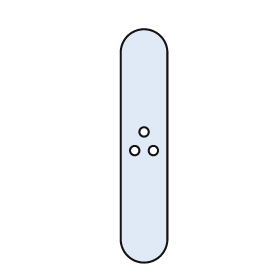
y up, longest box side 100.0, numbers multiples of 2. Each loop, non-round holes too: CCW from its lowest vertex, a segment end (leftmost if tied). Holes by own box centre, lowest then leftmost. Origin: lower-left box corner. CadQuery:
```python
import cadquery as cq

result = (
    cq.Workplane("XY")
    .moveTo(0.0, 10.0)
    .threePointArc((10.0, 0.0), (20.0, 10.0))
    .lineTo(20.0, 90.0)
    .threePointArc((10.0, 100.0), (0.0, 90.0))
    .close()
    .moveTo(6.0, 48.0)
    .circle(2.0)
    .moveTo(14.0, 48.0)
    .circle(2.0)
    .moveTo(10.0, 56.0)
    .circle(2.0)
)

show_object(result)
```